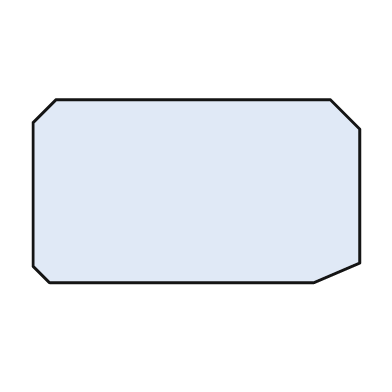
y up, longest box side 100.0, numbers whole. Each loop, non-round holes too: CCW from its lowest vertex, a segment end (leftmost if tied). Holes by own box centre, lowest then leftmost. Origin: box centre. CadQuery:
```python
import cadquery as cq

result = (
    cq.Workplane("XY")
    .moveTo(-45.0, -28.0)
    .lineTo(36.0, -28.0)
    .lineTo(50.0, -22.0)
    .lineTo(50.0, 19.0)
    .lineTo(41.0, 28.0)
    .lineTo(-43.0, 28.0)
    .lineTo(-50.0, 21.0)
    .lineTo(-50.0, -23.0)
    .close()
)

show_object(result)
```